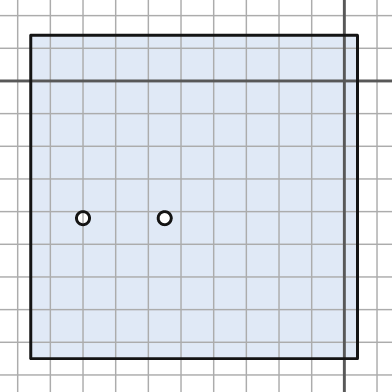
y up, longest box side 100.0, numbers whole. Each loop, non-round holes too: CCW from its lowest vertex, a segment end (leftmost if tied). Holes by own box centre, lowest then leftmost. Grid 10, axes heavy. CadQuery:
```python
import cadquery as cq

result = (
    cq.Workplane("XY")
    .moveTo(-96.0, -85.0)
    .lineTo(4.0, -85.0)
    .lineTo(4.0, 14.0)
    .lineTo(-96.0, 14.0)
    .close()
    .moveTo(-80.0, -42.0)
    .circle(2.0)
    .moveTo(-55.0, -42.0)
    .circle(2.0)
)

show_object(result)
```